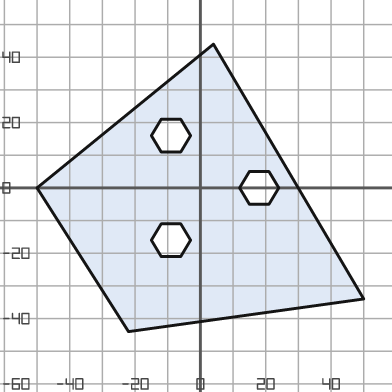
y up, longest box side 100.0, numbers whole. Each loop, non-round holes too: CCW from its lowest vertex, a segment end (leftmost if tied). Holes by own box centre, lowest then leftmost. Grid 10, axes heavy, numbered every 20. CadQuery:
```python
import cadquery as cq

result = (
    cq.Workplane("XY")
    .moveTo(-22.0, -44.0)
    .lineTo(50.0, -34.0)
    .lineTo(4.0, 44.0)
    .lineTo(-50.0, 0.0)
    .close()
    .moveTo(-12.0, -21.0)
    .lineTo(-6.0, -21.0)
    .lineTo(-3.0, -16.0)
    .lineTo(-6.0, -11.0)
    .lineTo(-12.0, -11.0)
    .lineTo(-15.0, -16.0)
    .close()
    .moveTo(15.0, -5.0)
    .lineTo(21.0, -5.0)
    .lineTo(24.0, 0.0)
    .lineTo(21.0, 5.0)
    .lineTo(15.0, 5.0)
    .lineTo(12.0, 0.0)
    .close()
    .moveTo(-12.0, 11.0)
    .lineTo(-6.0, 11.0)
    .lineTo(-3.0, 16.0)
    .lineTo(-6.0, 21.0)
    .lineTo(-12.0, 21.0)
    .lineTo(-15.0, 16.0)
    .close()
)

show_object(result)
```